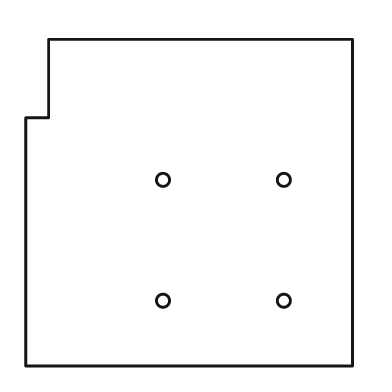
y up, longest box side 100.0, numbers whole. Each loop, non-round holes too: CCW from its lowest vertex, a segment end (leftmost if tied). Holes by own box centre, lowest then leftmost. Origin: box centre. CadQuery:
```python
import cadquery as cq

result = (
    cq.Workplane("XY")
    .moveTo(-50.0, -50.0)
    .lineTo(50.0, -50.0)
    .lineTo(50.0, 50.0)
    .lineTo(-43.0, 50.0)
    .lineTo(-43.0, 26.0)
    .lineTo(-50.0, 26.0)
    .close()
    .moveTo(-8.0, -30.0)
    .circle(2.0)
    .moveTo(29.0, -30.0)
    .circle(2.0)
    .moveTo(-8.0, 7.0)
    .circle(2.0)
    .moveTo(29.0, 7.0)
    .circle(2.0)
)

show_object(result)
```